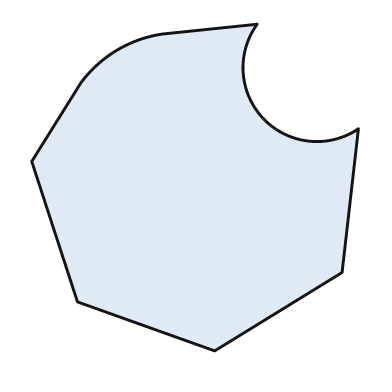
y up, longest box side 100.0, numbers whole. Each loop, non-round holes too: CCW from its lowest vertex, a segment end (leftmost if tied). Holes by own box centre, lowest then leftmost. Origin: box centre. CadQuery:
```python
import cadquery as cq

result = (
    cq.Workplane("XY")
    .moveTo(6.0, -50.0)
    .lineTo(45.0, -26.0)
    .lineTo(50.0, 18.0)
    .threePointArc((21.0, 21.0), (19.0, 50.0))
    .lineTo(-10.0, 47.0)
    .threePointArc((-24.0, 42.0), (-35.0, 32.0))
    .lineTo(-50.0, 8.0)
    .lineTo(-36.0, -35.0)
    .close()
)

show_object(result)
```